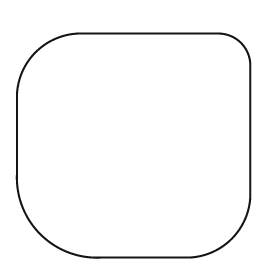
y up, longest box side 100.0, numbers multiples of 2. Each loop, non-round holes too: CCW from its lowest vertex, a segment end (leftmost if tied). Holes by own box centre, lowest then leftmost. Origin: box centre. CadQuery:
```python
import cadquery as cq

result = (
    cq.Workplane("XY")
    .moveTo(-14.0, -48.0)
    .lineTo(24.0, -48.0)
    .threePointArc((42.0, -40.0), (50.0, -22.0))
    .lineTo(50.0, 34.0)
    .threePointArc((46.0, 44.0), (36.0, 48.0))
    .lineTo(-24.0, 48.0)
    .threePointArc((-42.0, 40.0), (-50.0, 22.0))
    .lineTo(-50.0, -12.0)
    .threePointArc((-40.0, -38.0), (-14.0, -48.0))
    .close()
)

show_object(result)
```